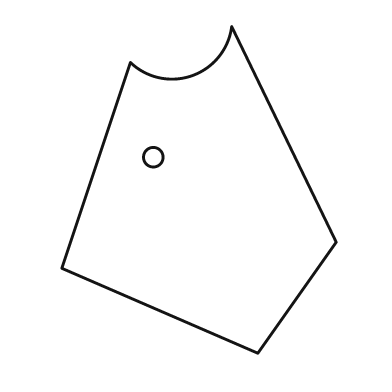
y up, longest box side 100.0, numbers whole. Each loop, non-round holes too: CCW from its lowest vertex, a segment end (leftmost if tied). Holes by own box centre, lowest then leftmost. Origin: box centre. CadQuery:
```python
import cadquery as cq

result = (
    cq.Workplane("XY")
    .moveTo(18.0, -50.0)
    .lineTo(42.0, -16.0)
    .lineTo(10.0, 50.0)
    .threePointArc((-2.0, 35.0), (-21.0, 39.0))
    .lineTo(-42.0, -24.0)
    .close()
    .moveTo(-14.0, 10.0)
    .circle(3.0)
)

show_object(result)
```